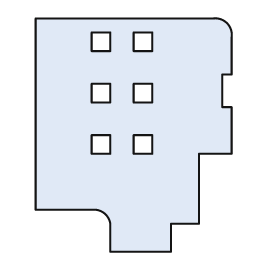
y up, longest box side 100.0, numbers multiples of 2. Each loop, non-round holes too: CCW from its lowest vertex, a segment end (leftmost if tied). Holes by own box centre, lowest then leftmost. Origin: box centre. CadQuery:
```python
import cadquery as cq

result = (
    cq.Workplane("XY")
    .moveTo(-10.0, -50.0)
    .lineTo(16.0, -50.0)
    .lineTo(16.0, -38.0)
    .lineTo(28.0, -38.0)
    .lineTo(28.0, -8.0)
    .lineTo(42.0, -8.0)
    .lineTo(42.0, 12.0)
    .lineTo(38.0, 12.0)
    .lineTo(38.0, 26.0)
    .lineTo(42.0, 26.0)
    .lineTo(42.0, 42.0)
    .threePointArc((40.0, 48.0), (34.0, 50.0))
    .lineTo(-42.0, 50.0)
    .lineTo(-42.0, -32.0)
    .lineTo(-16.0, -32.0)
    .threePointArc((-12.0, -34.0), (-10.0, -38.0))
    .close()
    .moveTo(-18.0, -8.0)
    .lineTo(-10.0, -8.0)
    .lineTo(-10.0, 0.0)
    .lineTo(-18.0, 0.0)
    .close()
    .moveTo(0.0, -8.0)
    .lineTo(8.0, -8.0)
    .lineTo(8.0, 0.0)
    .lineTo(0.0, 0.0)
    .close()
    .moveTo(-18.0, 14.0)
    .lineTo(-10.0, 14.0)
    .lineTo(-10.0, 22.0)
    .lineTo(-18.0, 22.0)
    .close()
    .moveTo(0.0, 14.0)
    .lineTo(8.0, 14.0)
    .lineTo(8.0, 22.0)
    .lineTo(0.0, 22.0)
    .close()
    .moveTo(-18.0, 36.0)
    .lineTo(-10.0, 36.0)
    .lineTo(-10.0, 44.0)
    .lineTo(-18.0, 44.0)
    .close()
    .moveTo(0.0, 36.0)
    .lineTo(8.0, 36.0)
    .lineTo(8.0, 44.0)
    .lineTo(0.0, 44.0)
    .close()
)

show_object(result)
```